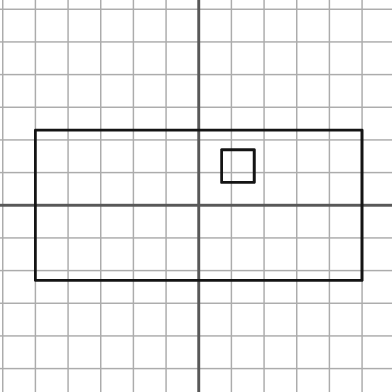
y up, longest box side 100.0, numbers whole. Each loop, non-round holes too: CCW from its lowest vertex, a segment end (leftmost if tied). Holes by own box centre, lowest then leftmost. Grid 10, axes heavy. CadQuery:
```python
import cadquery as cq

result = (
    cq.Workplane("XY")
    .moveTo(-50.0, -23.0)
    .lineTo(50.0, -23.0)
    .lineTo(50.0, 23.0)
    .lineTo(-50.0, 23.0)
    .close()
    .moveTo(7.0, 7.0)
    .lineTo(17.0, 7.0)
    .lineTo(17.0, 17.0)
    .lineTo(7.0, 17.0)
    .close()
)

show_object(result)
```